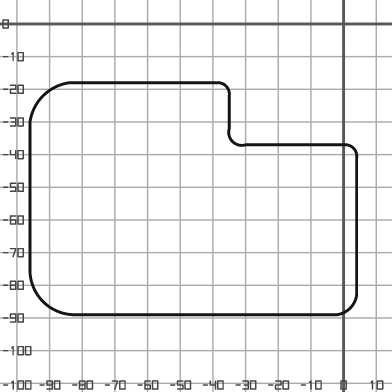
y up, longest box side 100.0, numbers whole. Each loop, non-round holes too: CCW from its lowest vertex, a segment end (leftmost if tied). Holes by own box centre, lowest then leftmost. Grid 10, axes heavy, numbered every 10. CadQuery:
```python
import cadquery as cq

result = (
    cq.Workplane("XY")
    .moveTo(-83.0, -89.0)
    .lineTo(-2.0, -89.0)
    .threePointArc((2.0, -87.0), (4.0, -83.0))
    .lineTo(4.0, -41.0)
    .threePointArc((3.0, -38.0), (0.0, -37.0))
    .lineTo(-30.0, -37.0)
    .threePointArc((-34.0, -36.0), (-35.0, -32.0))
    .lineTo(-35.0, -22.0)
    .threePointArc((-36.0, -19.0), (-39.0, -18.0))
    .lineTo(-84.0, -18.0)
    .threePointArc((-92.0, -22.0), (-96.0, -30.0))
    .lineTo(-96.0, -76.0)
    .threePointArc((-92.0, -85.0), (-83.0, -89.0))
    .close()
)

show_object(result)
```